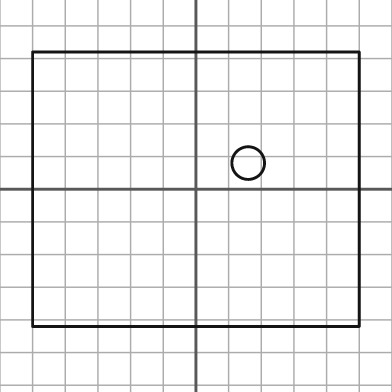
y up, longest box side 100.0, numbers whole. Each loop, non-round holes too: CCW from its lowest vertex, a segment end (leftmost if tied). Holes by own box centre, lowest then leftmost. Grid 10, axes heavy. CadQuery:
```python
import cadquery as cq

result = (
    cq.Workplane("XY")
    .moveTo(-50.0, -42.0)
    .lineTo(50.0, -42.0)
    .lineTo(50.0, 42.0)
    .lineTo(-50.0, 42.0)
    .close()
    .moveTo(16.0, 8.0)
    .circle(5.0)
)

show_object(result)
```